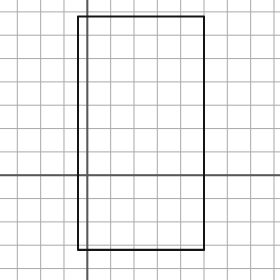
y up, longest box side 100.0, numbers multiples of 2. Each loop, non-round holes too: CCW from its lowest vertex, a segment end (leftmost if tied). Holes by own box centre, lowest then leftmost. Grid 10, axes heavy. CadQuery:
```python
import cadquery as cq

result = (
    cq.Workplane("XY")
    .moveTo(-4.0, -32.0)
    .lineTo(50.0, -32.0)
    .lineTo(50.0, 68.0)
    .lineTo(-4.0, 68.0)
    .close()
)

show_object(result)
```